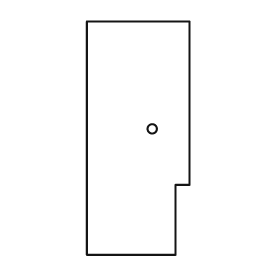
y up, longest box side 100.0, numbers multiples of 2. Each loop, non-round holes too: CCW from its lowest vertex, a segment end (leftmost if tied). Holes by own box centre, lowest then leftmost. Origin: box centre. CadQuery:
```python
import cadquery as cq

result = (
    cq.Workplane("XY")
    .moveTo(-22.0, -50.0)
    .lineTo(16.0, -50.0)
    .lineTo(16.0, -20.0)
    .lineTo(22.0, -20.0)
    .lineTo(22.0, 50.0)
    .lineTo(-22.0, 50.0)
    .close()
    .moveTo(6.0, 4.0)
    .circle(2.0)
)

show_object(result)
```